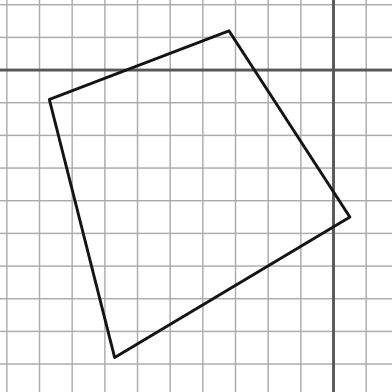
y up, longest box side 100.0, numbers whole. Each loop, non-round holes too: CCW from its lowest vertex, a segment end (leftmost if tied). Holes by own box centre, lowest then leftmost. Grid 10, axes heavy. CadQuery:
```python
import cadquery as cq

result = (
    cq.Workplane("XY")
    .moveTo(-67.0, -88.0)
    .lineTo(5.0, -45.0)
    .lineTo(-32.0, 12.0)
    .lineTo(-87.0, -9.0)
    .close()
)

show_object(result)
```